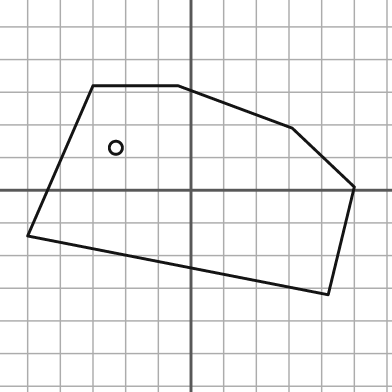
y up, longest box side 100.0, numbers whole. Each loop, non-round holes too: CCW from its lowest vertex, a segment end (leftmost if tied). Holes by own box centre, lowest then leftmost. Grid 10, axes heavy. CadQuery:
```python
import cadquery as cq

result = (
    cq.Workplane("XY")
    .moveTo(42.0, -32.0)
    .lineTo(50.0, 1.0)
    .lineTo(31.0, 19.0)
    .lineTo(-4.0, 32.0)
    .lineTo(-30.0, 32.0)
    .lineTo(-50.0, -14.0)
    .close()
    .moveTo(-23.0, 13.0)
    .circle(2.0)
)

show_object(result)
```